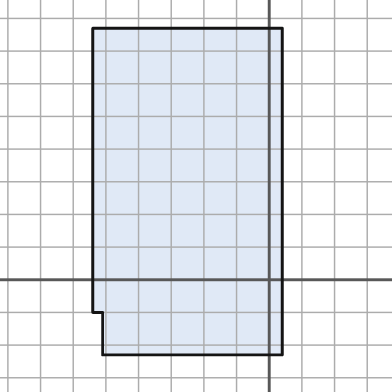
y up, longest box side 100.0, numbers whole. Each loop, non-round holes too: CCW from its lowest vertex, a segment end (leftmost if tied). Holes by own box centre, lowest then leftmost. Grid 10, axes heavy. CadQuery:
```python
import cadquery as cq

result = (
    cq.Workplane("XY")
    .moveTo(-51.0, -23.0)
    .lineTo(4.0, -23.0)
    .lineTo(4.0, 77.0)
    .lineTo(-54.0, 77.0)
    .lineTo(-54.0, -10.0)
    .lineTo(-51.0, -10.0)
    .close()
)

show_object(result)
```